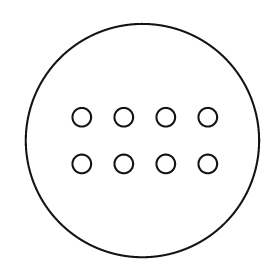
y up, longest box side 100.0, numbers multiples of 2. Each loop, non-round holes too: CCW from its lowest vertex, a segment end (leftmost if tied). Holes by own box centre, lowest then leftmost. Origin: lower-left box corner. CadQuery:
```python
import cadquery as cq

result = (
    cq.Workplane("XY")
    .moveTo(50.0, 50.0)
    .circle(50.0)
    .moveTo(24.0, 40.0)
    .circle(4.0)
    .moveTo(42.0, 40.0)
    .circle(4.0)
    .moveTo(60.0, 40.0)
    .circle(4.0)
    .moveTo(78.0, 40.0)
    .circle(4.0)
    .moveTo(24.0, 60.0)
    .circle(4.0)
    .moveTo(42.0, 60.0)
    .circle(4.0)
    .moveTo(60.0, 60.0)
    .circle(4.0)
    .moveTo(78.0, 60.0)
    .circle(4.0)
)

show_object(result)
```